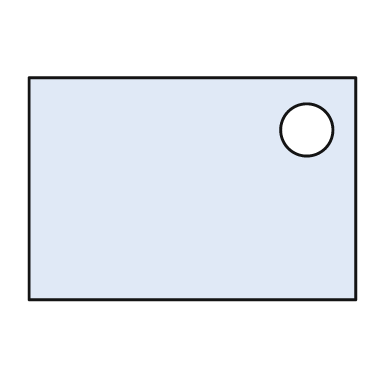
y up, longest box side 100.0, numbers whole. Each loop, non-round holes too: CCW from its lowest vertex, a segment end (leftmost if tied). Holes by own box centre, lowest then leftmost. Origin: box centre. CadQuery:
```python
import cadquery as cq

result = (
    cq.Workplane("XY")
    .moveTo(-50.0, -34.0)
    .lineTo(50.0, -34.0)
    .lineTo(50.0, 34.0)
    .lineTo(-50.0, 34.0)
    .close()
    .moveTo(35.0, 18.0)
    .circle(8.0)
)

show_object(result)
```